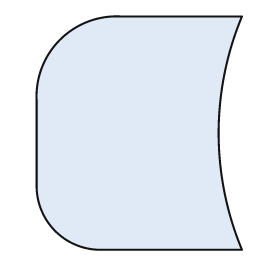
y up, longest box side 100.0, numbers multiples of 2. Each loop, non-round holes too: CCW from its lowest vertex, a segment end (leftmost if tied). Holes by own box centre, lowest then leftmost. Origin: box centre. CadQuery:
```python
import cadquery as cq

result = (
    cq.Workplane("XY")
    .moveTo(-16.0, -50.0)
    .lineTo(44.0, -50.0)
    .threePointArc((34.0, 0.0), (44.0, 50.0))
    .lineTo(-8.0, 50.0)
    .threePointArc((-34.0, 40.0), (-44.0, 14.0))
    .lineTo(-44.0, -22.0)
    .threePointArc((-36.0, -42.0), (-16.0, -50.0))
    .close()
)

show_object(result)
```